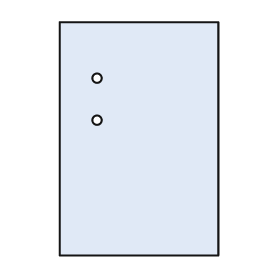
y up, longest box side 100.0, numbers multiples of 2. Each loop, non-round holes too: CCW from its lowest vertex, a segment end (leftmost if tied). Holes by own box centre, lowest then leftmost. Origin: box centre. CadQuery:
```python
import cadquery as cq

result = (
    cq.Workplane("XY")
    .moveTo(-34.0, -50.0)
    .lineTo(34.0, -50.0)
    .lineTo(34.0, 50.0)
    .lineTo(-34.0, 50.0)
    .close()
    .moveTo(-18.0, 8.0)
    .circle(2.0)
    .moveTo(-18.0, 26.0)
    .circle(2.0)
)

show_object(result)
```